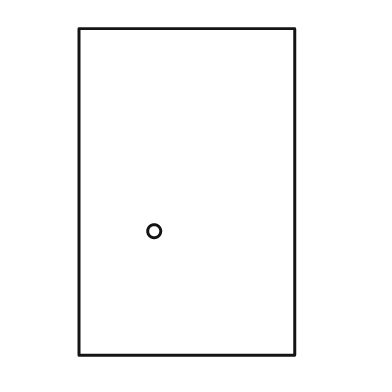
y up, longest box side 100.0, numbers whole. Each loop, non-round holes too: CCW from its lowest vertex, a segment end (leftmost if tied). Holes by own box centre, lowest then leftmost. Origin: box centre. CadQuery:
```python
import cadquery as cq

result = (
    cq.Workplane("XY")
    .moveTo(-33.0, -50.0)
    .lineTo(33.0, -50.0)
    .lineTo(33.0, 50.0)
    .lineTo(-33.0, 50.0)
    .close()
    .moveTo(-10.0, -12.0)
    .circle(2.0)
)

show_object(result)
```